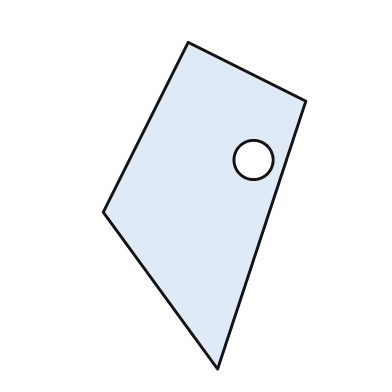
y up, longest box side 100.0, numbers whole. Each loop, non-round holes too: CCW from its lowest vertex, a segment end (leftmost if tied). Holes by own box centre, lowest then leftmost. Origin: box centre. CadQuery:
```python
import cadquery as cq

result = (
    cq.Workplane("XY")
    .moveTo(4.0, -50.0)
    .lineTo(31.0, 32.0)
    .lineTo(-5.0, 50.0)
    .lineTo(-31.0, -2.0)
    .close()
    .moveTo(15.0, 14.0)
    .circle(6.0)
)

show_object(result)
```